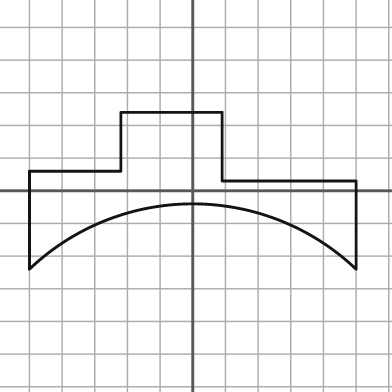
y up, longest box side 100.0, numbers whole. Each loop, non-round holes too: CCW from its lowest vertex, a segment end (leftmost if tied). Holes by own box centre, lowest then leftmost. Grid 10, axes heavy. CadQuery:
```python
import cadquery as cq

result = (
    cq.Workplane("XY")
    .moveTo(-50.0, -24.0)
    .threePointArc((0.0, -4.0), (50.0, -24.0))
    .lineTo(50.0, 3.0)
    .lineTo(9.0, 3.0)
    .lineTo(9.0, 24.0)
    .lineTo(-22.0, 24.0)
    .lineTo(-22.0, 6.0)
    .lineTo(-50.0, 6.0)
    .close()
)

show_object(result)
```